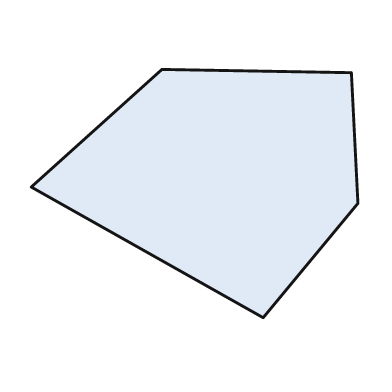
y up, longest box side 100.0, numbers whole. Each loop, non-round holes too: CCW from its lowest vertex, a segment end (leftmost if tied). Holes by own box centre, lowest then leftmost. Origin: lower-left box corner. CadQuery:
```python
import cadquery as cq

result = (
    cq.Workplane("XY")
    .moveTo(71.0, 0.0)
    .lineTo(100.0, 35.0)
    .lineTo(98.0, 75.0)
    .lineTo(40.0, 76.0)
    .lineTo(0.0, 40.0)
    .close()
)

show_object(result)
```